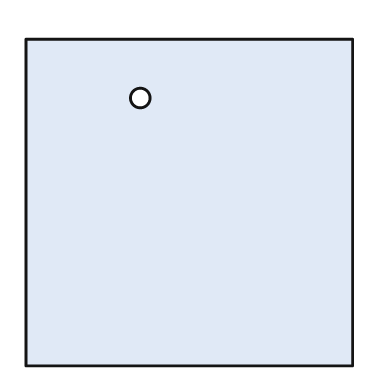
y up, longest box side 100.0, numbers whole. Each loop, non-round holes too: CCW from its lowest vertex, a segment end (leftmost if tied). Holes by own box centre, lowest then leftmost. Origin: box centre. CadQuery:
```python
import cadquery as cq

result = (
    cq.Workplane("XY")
    .moveTo(-50.0, -50.0)
    .lineTo(50.0, -50.0)
    .lineTo(50.0, 50.0)
    .lineTo(-50.0, 50.0)
    .close()
    .moveTo(-15.0, 32.0)
    .circle(3.0)
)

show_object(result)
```